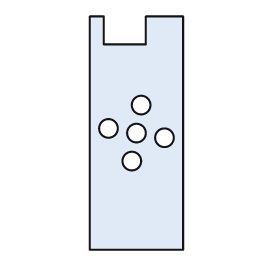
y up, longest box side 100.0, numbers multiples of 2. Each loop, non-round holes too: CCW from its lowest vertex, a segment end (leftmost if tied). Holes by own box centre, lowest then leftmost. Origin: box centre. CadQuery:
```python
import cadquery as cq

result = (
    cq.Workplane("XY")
    .moveTo(-20.0, -50.0)
    .lineTo(20.0, -50.0)
    .lineTo(20.0, 50.0)
    .lineTo(4.0, 50.0)
    .lineTo(4.0, 38.0)
    .lineTo(-14.0, 38.0)
    .lineTo(-14.0, 50.0)
    .lineTo(-20.0, 50.0)
    .close()
    .moveTo(-2.0, -12.0)
    .circle(4.0)
    .moveTo(12.0, -2.0)
    .circle(4.0)
    .moveTo(0.0, 0.0)
    .circle(4.0)
    .moveTo(-12.0, 2.0)
    .circle(4.0)
    .moveTo(2.0, 12.0)
    .circle(4.0)
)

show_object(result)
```